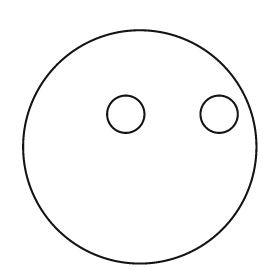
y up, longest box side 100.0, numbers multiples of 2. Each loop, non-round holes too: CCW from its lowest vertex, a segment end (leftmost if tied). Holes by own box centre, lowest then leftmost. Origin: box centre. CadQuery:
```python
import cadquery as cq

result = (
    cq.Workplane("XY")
    .moveTo(0.0, 0.0)
    .circle(50.0)
    .moveTo(-6.0, 14.0)
    .circle(8.0)
    .moveTo(34.0, 14.0)
    .circle(8.0)
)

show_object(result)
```